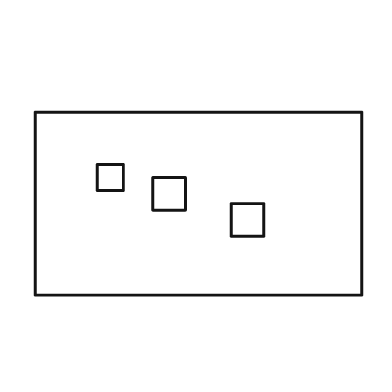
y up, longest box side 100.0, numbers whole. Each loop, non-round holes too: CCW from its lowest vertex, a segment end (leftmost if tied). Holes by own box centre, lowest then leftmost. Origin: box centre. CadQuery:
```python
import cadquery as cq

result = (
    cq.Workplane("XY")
    .moveTo(-50.0, -28.0)
    .lineTo(50.0, -28.0)
    .lineTo(50.0, 28.0)
    .lineTo(-50.0, 28.0)
    .close()
    .moveTo(10.0, -10.0)
    .lineTo(20.0, -10.0)
    .lineTo(20.0, 0.0)
    .lineTo(10.0, 0.0)
    .close()
    .moveTo(-14.0, -2.0)
    .lineTo(-4.0, -2.0)
    .lineTo(-4.0, 8.0)
    .lineTo(-14.0, 8.0)
    .close()
    .moveTo(-31.0, 4.0)
    .lineTo(-23.0, 4.0)
    .lineTo(-23.0, 12.0)
    .lineTo(-31.0, 12.0)
    .close()
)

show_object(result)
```